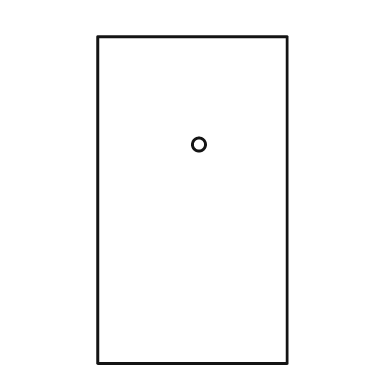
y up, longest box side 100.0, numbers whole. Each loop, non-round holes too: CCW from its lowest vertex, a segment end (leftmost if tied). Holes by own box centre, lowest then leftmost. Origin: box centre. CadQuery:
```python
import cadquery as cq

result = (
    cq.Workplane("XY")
    .moveTo(-29.0, -50.0)
    .lineTo(29.0, -50.0)
    .lineTo(29.0, 50.0)
    .lineTo(-29.0, 50.0)
    .close()
    .moveTo(2.0, 17.0)
    .circle(2.0)
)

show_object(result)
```